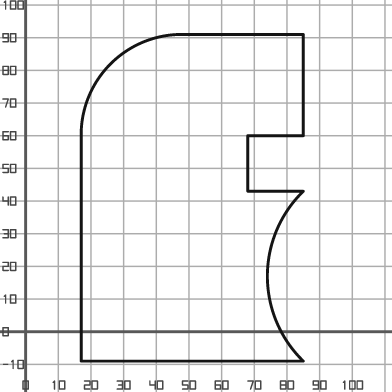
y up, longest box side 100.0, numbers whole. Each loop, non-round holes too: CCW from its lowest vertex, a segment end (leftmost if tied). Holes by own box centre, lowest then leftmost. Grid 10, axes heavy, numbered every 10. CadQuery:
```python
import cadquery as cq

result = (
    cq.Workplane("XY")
    .moveTo(17.0, -9.0)
    .lineTo(85.0, -9.0)
    .threePointArc((74.0, 17.0), (85.0, 43.0))
    .lineTo(68.0, 43.0)
    .lineTo(68.0, 60.0)
    .lineTo(85.0, 60.0)
    .lineTo(85.0, 91.0)
    .lineTo(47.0, 91.0)
    .threePointArc((26.0, 82.0), (17.0, 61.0))
    .close()
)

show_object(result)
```